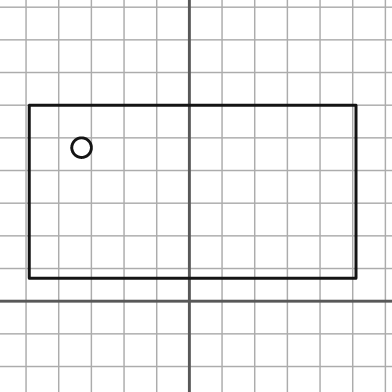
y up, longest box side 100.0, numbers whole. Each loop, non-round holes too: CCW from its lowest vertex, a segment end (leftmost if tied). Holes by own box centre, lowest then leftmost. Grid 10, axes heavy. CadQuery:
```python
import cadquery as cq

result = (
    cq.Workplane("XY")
    .moveTo(-49.0, 7.0)
    .lineTo(51.0, 7.0)
    .lineTo(51.0, 60.0)
    .lineTo(-49.0, 60.0)
    .close()
    .moveTo(-33.0, 47.0)
    .circle(3.0)
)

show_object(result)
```